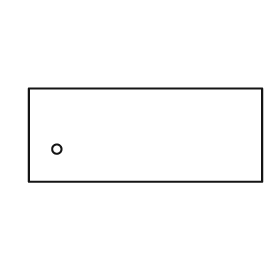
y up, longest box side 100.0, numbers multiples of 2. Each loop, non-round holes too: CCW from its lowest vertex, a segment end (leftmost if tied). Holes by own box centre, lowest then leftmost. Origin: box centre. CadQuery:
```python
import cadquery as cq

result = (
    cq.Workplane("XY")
    .moveTo(-50.0, -20.0)
    .lineTo(50.0, -20.0)
    .lineTo(50.0, 20.0)
    .lineTo(-50.0, 20.0)
    .close()
    .moveTo(-38.0, -6.0)
    .circle(2.0)
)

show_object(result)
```